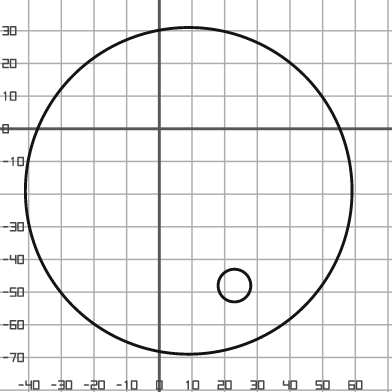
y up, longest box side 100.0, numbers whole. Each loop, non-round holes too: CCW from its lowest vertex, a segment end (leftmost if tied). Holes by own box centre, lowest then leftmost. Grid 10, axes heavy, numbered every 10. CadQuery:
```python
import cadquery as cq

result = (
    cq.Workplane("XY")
    .moveTo(9.0, -19.0)
    .circle(50.0)
    .moveTo(23.0, -48.0)
    .circle(5.0)
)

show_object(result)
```